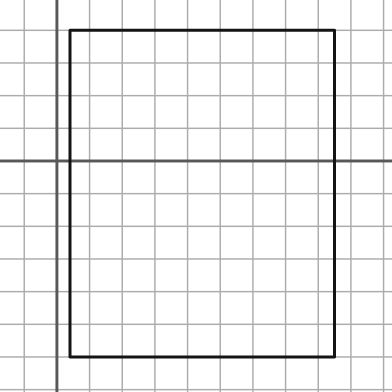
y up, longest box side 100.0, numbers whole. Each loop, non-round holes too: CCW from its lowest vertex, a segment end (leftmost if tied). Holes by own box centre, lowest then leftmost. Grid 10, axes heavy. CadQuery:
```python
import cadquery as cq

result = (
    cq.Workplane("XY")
    .moveTo(4.0, -60.0)
    .lineTo(85.0, -60.0)
    .lineTo(85.0, 40.0)
    .lineTo(4.0, 40.0)
    .close()
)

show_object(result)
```